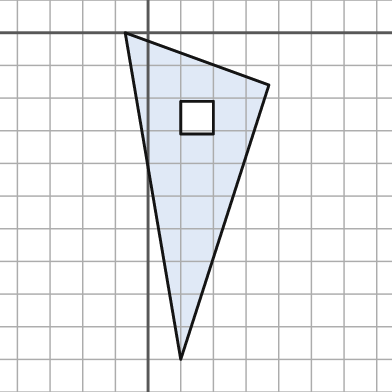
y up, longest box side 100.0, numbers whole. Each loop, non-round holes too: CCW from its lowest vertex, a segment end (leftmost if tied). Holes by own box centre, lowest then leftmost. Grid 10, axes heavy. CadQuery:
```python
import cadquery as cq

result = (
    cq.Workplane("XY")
    .moveTo(10.0, -100.0)
    .lineTo(37.0, -16.0)
    .lineTo(-7.0, 0.0)
    .close()
    .moveTo(10.0, -31.0)
    .lineTo(20.0, -31.0)
    .lineTo(20.0, -21.0)
    .lineTo(10.0, -21.0)
    .close()
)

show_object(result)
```